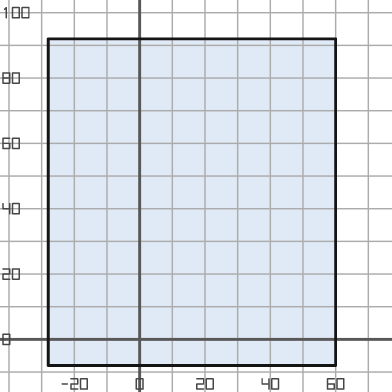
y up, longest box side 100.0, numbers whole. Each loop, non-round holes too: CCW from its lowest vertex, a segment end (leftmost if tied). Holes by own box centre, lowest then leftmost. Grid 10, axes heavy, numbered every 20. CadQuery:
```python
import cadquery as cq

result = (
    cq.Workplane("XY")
    .moveTo(-28.0, -8.0)
    .lineTo(60.0, -8.0)
    .lineTo(60.0, 92.0)
    .lineTo(-28.0, 92.0)
    .close()
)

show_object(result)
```